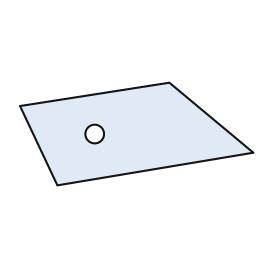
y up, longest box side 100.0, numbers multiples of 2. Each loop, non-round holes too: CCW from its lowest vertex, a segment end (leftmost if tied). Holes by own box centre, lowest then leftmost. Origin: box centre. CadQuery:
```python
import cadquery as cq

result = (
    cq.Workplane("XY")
    .moveTo(-34.0, -22.0)
    .lineTo(50.0, -8.0)
    .lineTo(14.0, 22.0)
    .lineTo(-50.0, 12.0)
    .close()
    .moveTo(-18.0, 0.0)
    .circle(4.0)
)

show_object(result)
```